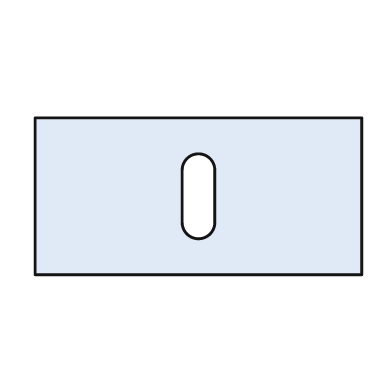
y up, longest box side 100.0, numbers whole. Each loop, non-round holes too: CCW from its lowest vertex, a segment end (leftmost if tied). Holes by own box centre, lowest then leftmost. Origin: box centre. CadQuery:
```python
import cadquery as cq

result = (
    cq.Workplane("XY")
    .moveTo(-50.0, -24.0)
    .lineTo(50.0, -24.0)
    .lineTo(50.0, 24.0)
    .lineTo(-50.0, 24.0)
    .close()
    .moveTo(-5.0, -8.0)
    .threePointArc((0.0, -13.0), (5.0, -8.0))
    .lineTo(5.0, 8.0)
    .threePointArc((0.0, 13.0), (-5.0, 8.0))
    .close()
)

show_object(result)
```